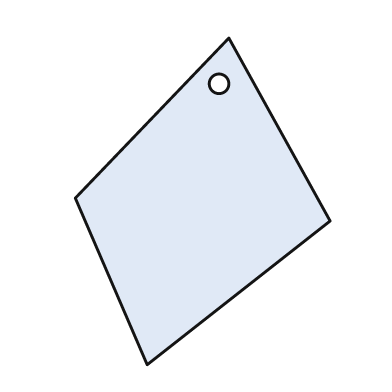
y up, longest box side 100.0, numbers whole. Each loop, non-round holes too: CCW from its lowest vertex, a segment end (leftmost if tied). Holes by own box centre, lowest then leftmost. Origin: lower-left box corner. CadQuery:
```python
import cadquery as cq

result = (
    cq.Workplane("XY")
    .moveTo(22.0, 0.0)
    .lineTo(78.0, 44.0)
    .lineTo(47.0, 100.0)
    .lineTo(0.0, 51.0)
    .close()
    .moveTo(44.0, 86.0)
    .circle(3.0)
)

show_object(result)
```